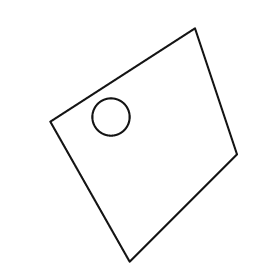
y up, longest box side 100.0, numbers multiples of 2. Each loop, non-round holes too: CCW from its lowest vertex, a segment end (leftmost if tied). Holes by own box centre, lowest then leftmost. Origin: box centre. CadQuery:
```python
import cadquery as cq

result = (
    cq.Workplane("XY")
    .moveTo(-6.0, -50.0)
    .lineTo(40.0, -4.0)
    .lineTo(22.0, 50.0)
    .lineTo(-40.0, 10.0)
    .close()
    .moveTo(-14.0, 12.0)
    .circle(8.0)
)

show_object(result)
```